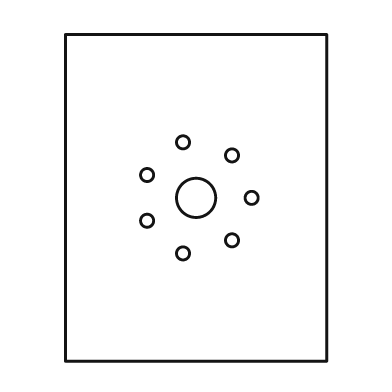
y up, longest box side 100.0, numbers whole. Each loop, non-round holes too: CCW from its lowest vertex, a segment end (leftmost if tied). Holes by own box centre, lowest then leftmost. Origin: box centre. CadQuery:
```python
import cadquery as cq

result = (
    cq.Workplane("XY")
    .moveTo(-40.0, -50.0)
    .lineTo(40.0, -50.0)
    .lineTo(40.0, 50.0)
    .lineTo(-40.0, 50.0)
    .close()
    .moveTo(-4.0, -17.0)
    .circle(2.0)
    .moveTo(11.0, -13.0)
    .circle(2.0)
    .moveTo(-15.0, -7.0)
    .circle(2.0)
    .moveTo(0.0, 0.0)
    .circle(6.0)
    .moveTo(17.0, 0.0)
    .circle(2.0)
    .moveTo(-15.0, 7.0)
    .circle(2.0)
    .moveTo(11.0, 13.0)
    .circle(2.0)
    .moveTo(-4.0, 17.0)
    .circle(2.0)
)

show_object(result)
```